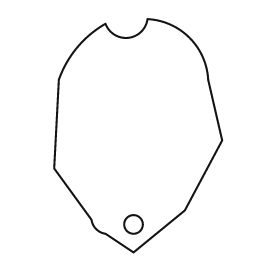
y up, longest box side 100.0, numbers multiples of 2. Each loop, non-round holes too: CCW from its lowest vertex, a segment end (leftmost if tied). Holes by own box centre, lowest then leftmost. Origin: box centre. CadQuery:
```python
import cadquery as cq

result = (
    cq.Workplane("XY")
    .moveTo(-2.0, -50.0)
    .lineTo(20.0, -32.0)
    .lineTo(36.0, -2.0)
    .lineTo(30.0, 24.0)
    .threePointArc((22.0, 42.0), (4.0, 50.0))
    .threePointArc((-4.0, 42.0), (-14.0, 48.0))
    .threePointArc((-26.0, 38.0), (-34.0, 24.0))
    .lineTo(-36.0, -14.0)
    .lineTo(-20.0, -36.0)
    .threePointArc((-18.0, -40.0), (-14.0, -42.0))
    .close()
    .moveTo(-2.0, -38.0)
    .circle(4.0)
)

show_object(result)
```